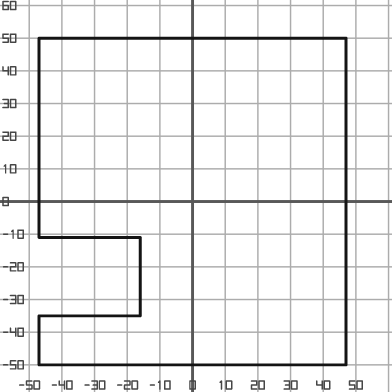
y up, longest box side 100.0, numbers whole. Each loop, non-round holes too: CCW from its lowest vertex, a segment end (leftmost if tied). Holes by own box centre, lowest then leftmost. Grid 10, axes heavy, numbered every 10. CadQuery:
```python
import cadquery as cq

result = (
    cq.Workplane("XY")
    .moveTo(-47.0, -50.0)
    .lineTo(47.0, -50.0)
    .lineTo(47.0, 50.0)
    .lineTo(-47.0, 50.0)
    .lineTo(-47.0, -11.0)
    .lineTo(-16.0, -11.0)
    .lineTo(-16.0, -35.0)
    .lineTo(-47.0, -35.0)
    .close()
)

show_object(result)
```